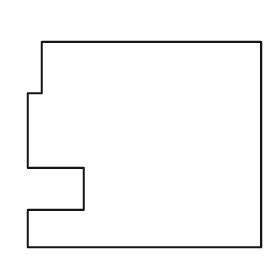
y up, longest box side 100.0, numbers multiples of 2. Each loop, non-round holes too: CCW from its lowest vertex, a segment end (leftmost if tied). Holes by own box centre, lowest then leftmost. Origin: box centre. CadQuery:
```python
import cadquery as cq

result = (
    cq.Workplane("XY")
    .moveTo(-50.0, -44.0)
    .lineTo(50.0, -44.0)
    .lineTo(50.0, 44.0)
    .lineTo(-44.0, 44.0)
    .lineTo(-44.0, 22.0)
    .lineTo(-50.0, 22.0)
    .lineTo(-50.0, -10.0)
    .lineTo(-26.0, -10.0)
    .lineTo(-26.0, -28.0)
    .lineTo(-50.0, -28.0)
    .close()
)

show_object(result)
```